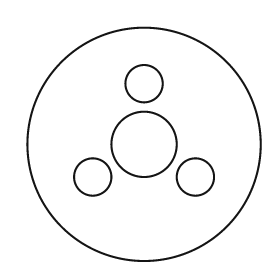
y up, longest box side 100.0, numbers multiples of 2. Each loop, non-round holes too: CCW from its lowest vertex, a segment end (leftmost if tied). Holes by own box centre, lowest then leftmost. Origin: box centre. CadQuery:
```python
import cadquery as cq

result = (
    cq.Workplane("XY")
    .moveTo(0.0, 0.0)
    .circle(50.0)
    .moveTo(-22.0, -14.0)
    .circle(8.0)
    .moveTo(22.0, -14.0)
    .circle(8.0)
    .moveTo(0.0, 0.0)
    .circle(14.0)
    .moveTo(0.0, 26.0)
    .circle(8.0)
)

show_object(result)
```